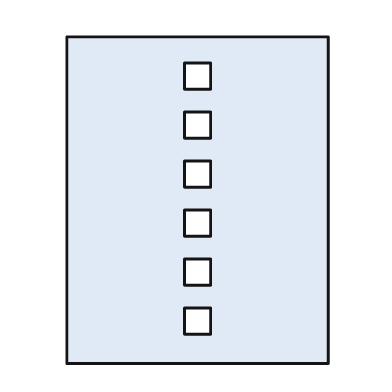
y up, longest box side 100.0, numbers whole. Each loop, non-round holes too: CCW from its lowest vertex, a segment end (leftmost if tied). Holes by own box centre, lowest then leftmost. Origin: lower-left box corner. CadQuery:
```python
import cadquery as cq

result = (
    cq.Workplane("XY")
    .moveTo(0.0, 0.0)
    .lineTo(80.0, 0.0)
    .lineTo(80.0, 100.0)
    .lineTo(0.0, 100.0)
    .close()
    .moveTo(36.0, 9.0)
    .lineTo(44.0, 9.0)
    .lineTo(44.0, 17.0)
    .lineTo(36.0, 17.0)
    .close()
    .moveTo(36.0, 24.0)
    .lineTo(44.0, 24.0)
    .lineTo(44.0, 32.0)
    .lineTo(36.0, 32.0)
    .close()
    .moveTo(36.0, 39.0)
    .lineTo(44.0, 39.0)
    .lineTo(44.0, 47.0)
    .lineTo(36.0, 47.0)
    .close()
    .moveTo(36.0, 54.0)
    .lineTo(44.0, 54.0)
    .lineTo(44.0, 62.0)
    .lineTo(36.0, 62.0)
    .close()
    .moveTo(36.0, 69.0)
    .lineTo(44.0, 69.0)
    .lineTo(44.0, 77.0)
    .lineTo(36.0, 77.0)
    .close()
    .moveTo(36.0, 84.0)
    .lineTo(44.0, 84.0)
    .lineTo(44.0, 92.0)
    .lineTo(36.0, 92.0)
    .close()
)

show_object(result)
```